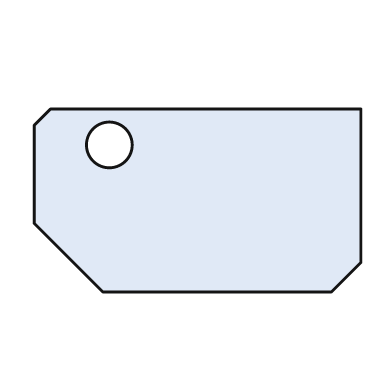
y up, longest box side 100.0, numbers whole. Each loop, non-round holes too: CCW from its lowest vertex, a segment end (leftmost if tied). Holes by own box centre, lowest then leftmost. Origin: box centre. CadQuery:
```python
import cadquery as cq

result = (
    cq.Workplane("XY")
    .moveTo(-29.0, -28.0)
    .lineTo(41.0, -28.0)
    .lineTo(50.0, -19.0)
    .lineTo(50.0, 28.0)
    .lineTo(-45.0, 28.0)
    .lineTo(-50.0, 23.0)
    .lineTo(-50.0, -7.0)
    .close()
    .moveTo(-27.0, 17.0)
    .circle(7.0)
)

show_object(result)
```